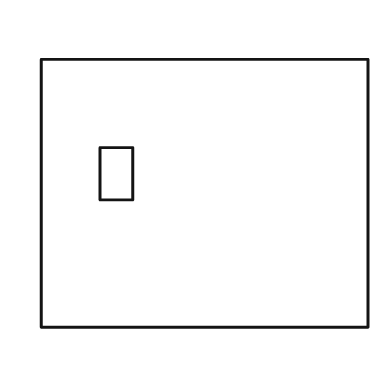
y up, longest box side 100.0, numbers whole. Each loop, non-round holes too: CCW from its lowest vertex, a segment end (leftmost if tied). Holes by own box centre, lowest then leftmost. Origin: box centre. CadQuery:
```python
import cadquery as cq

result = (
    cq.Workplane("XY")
    .moveTo(-50.0, -41.0)
    .lineTo(50.0, -41.0)
    .lineTo(50.0, 41.0)
    .lineTo(-50.0, 41.0)
    .close()
    .moveTo(-32.0, -2.0)
    .lineTo(-22.0, -2.0)
    .lineTo(-22.0, 14.0)
    .lineTo(-32.0, 14.0)
    .close()
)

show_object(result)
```